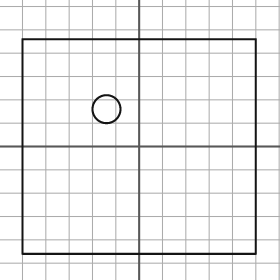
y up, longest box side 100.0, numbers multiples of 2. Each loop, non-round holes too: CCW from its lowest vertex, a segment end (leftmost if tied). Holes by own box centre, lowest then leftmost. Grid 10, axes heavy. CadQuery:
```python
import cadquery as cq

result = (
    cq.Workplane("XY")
    .moveTo(-50.0, -46.0)
    .lineTo(50.0, -46.0)
    .lineTo(50.0, 46.0)
    .lineTo(-50.0, 46.0)
    .close()
    .moveTo(-14.0, 16.0)
    .circle(6.0)
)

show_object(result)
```